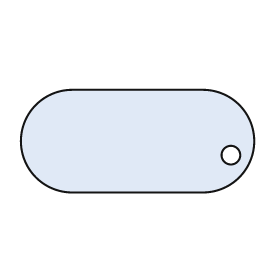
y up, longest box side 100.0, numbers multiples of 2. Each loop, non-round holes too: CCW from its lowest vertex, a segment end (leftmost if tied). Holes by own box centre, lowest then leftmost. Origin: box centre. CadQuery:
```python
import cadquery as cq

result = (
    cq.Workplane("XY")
    .moveTo(-28.0, -22.0)
    .lineTo(28.0, -22.0)
    .threePointArc((50.0, 0.0), (28.0, 22.0))
    .lineTo(-28.0, 22.0)
    .threePointArc((-50.0, 0.0), (-28.0, -22.0))
    .close()
    .moveTo(40.0, -6.0)
    .circle(4.0)
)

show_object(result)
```